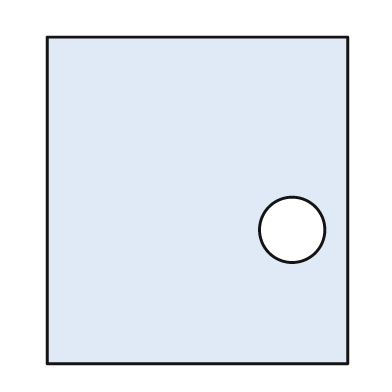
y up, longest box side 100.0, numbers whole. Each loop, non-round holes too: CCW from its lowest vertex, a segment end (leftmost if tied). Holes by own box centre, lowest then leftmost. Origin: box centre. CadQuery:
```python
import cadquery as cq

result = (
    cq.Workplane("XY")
    .moveTo(-46.0, -50.0)
    .lineTo(46.0, -50.0)
    .lineTo(46.0, 50.0)
    .lineTo(-46.0, 50.0)
    .close()
    .moveTo(29.0, -9.0)
    .circle(10.0)
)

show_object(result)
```